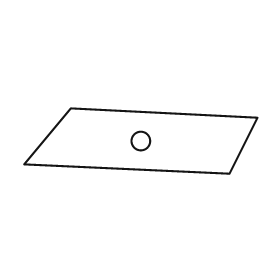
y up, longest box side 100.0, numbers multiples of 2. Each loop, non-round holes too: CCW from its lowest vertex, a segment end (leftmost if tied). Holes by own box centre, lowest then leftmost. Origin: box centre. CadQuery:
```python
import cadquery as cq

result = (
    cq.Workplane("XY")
    .moveTo(38.0, -14.0)
    .lineTo(50.0, 10.0)
    .lineTo(-30.0, 14.0)
    .lineTo(-50.0, -10.0)
    .close()
    .moveTo(0.0, 0.0)
    .circle(4.0)
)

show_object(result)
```